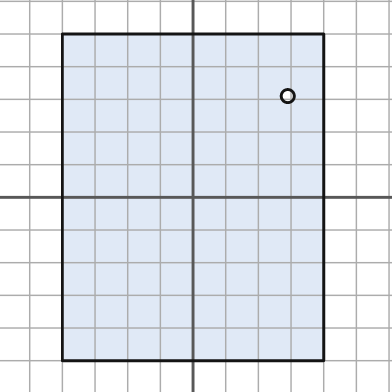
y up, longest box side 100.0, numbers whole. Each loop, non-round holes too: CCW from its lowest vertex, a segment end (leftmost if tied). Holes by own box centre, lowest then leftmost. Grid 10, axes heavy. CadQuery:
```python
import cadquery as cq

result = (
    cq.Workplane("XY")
    .moveTo(-40.0, -50.0)
    .lineTo(40.0, -50.0)
    .lineTo(40.0, 50.0)
    .lineTo(-40.0, 50.0)
    .close()
    .moveTo(29.0, 31.0)
    .circle(2.0)
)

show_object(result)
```